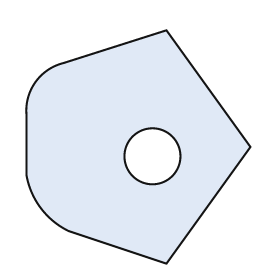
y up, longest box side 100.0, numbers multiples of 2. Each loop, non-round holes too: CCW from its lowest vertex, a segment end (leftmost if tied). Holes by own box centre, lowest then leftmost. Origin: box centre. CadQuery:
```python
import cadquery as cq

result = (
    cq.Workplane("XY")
    .moveTo(12.0, -50.0)
    .lineTo(48.0, 0.0)
    .lineTo(12.0, 50.0)
    .lineTo(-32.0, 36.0)
    .threePointArc((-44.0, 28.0), (-48.0, 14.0))
    .lineTo(-48.0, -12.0)
    .threePointArc((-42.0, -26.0), (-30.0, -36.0))
    .close()
    .moveTo(6.0, -4.0)
    .circle(12.0)
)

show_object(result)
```